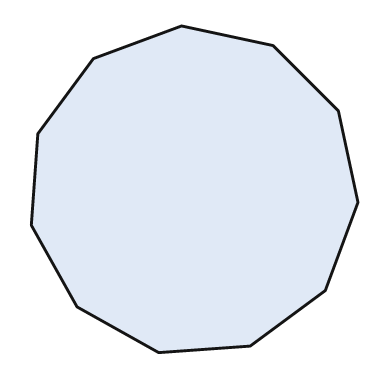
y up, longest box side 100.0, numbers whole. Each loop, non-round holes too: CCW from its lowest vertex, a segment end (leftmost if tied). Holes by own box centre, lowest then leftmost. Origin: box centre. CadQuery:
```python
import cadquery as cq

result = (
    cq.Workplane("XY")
    .moveTo(-11.0, -50.0)
    .lineTo(17.0, -48.0)
    .lineTo(40.0, -31.0)
    .lineTo(50.0, -4.0)
    .lineTo(44.0, 24.0)
    .lineTo(24.0, 44.0)
    .lineTo(-4.0, 50.0)
    .lineTo(-31.0, 40.0)
    .lineTo(-48.0, 17.0)
    .lineTo(-50.0, -11.0)
    .lineTo(-36.0, -36.0)
    .close()
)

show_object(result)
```